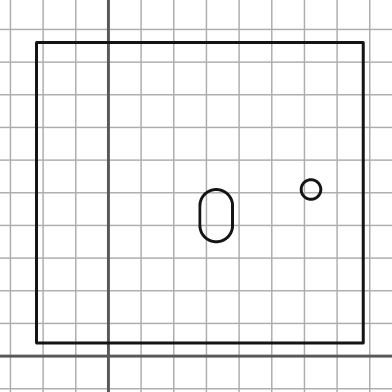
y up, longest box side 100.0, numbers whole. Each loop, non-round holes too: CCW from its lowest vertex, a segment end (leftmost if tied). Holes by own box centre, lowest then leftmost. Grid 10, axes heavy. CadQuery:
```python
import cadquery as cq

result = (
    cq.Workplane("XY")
    .moveTo(-22.0, 4.0)
    .lineTo(78.0, 4.0)
    .lineTo(78.0, 96.0)
    .lineTo(-22.0, 96.0)
    .close()
    .moveTo(28.0, 40.0)
    .threePointArc((33.0, 35.0), (38.0, 40.0))
    .lineTo(38.0, 46.0)
    .threePointArc((33.0, 51.0), (28.0, 46.0))
    .close()
    .moveTo(62.0, 51.0)
    .circle(3.0)
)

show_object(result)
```